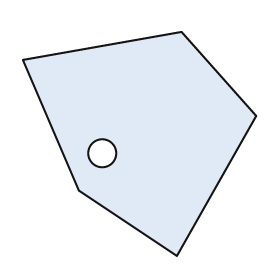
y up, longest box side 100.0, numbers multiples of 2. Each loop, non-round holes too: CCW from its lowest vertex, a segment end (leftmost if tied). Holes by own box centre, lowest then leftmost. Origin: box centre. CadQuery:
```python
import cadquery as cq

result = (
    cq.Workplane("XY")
    .moveTo(16.0, -48.0)
    .lineTo(50.0, 12.0)
    .lineTo(18.0, 48.0)
    .lineTo(-50.0, 36.0)
    .lineTo(-26.0, -20.0)
    .close()
    .moveTo(-16.0, -4.0)
    .circle(6.0)
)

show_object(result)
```